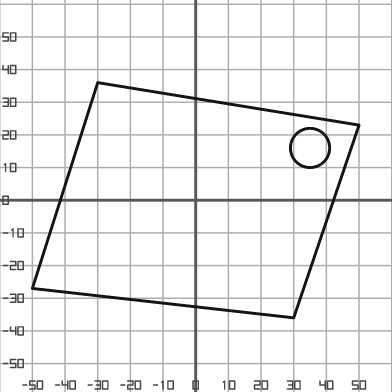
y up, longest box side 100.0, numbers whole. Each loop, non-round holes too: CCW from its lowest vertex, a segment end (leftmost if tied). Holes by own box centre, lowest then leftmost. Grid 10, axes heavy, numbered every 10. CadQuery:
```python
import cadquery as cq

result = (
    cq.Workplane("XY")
    .moveTo(30.0, -36.0)
    .lineTo(50.0, 23.0)
    .lineTo(-30.0, 36.0)
    .lineTo(-50.0, -27.0)
    .close()
    .moveTo(35.0, 16.0)
    .circle(6.0)
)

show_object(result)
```